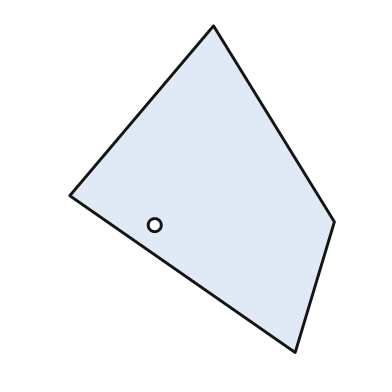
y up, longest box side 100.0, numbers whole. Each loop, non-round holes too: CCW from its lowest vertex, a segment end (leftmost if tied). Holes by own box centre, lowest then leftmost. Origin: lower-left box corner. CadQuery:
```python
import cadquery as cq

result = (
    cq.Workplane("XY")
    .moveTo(69.0, 0.0)
    .lineTo(81.0, 40.0)
    .lineTo(44.0, 100.0)
    .lineTo(0.0, 48.0)
    .close()
    .moveTo(26.0, 39.0)
    .circle(2.0)
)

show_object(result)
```